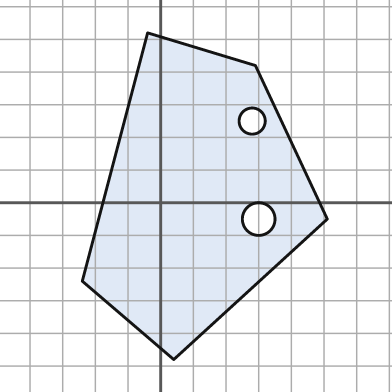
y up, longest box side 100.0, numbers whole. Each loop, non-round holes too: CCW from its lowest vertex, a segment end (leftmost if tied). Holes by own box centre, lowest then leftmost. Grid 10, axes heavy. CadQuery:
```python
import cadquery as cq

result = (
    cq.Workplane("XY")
    .moveTo(4.0, -48.0)
    .lineTo(51.0, -5.0)
    .lineTo(29.0, 42.0)
    .lineTo(-4.0, 52.0)
    .lineTo(-24.0, -24.0)
    .close()
    .moveTo(30.0, -5.0)
    .circle(5.0)
    .moveTo(28.0, 25.0)
    .circle(4.0)
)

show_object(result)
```